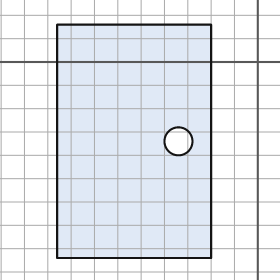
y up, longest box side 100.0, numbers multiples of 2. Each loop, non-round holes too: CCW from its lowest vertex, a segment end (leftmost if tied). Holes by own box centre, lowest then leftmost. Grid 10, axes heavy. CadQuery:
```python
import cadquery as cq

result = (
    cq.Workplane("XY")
    .moveTo(-86.0, -84.0)
    .lineTo(-20.0, -84.0)
    .lineTo(-20.0, 16.0)
    .lineTo(-86.0, 16.0)
    .close()
    .moveTo(-34.0, -34.0)
    .circle(6.0)
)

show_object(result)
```